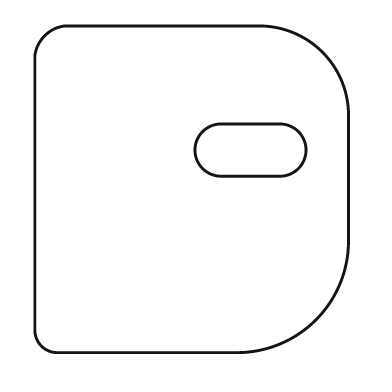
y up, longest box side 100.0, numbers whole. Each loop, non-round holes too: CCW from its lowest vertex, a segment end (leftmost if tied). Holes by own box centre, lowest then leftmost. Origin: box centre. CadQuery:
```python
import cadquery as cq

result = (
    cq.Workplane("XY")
    .moveTo(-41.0, -50.0)
    .lineTo(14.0, -50.0)
    .threePointArc((38.0, -40.0), (48.0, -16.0))
    .lineTo(48.0, 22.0)
    .threePointArc((40.0, 42.0), (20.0, 50.0))
    .lineTo(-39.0, 50.0)
    .threePointArc((-45.0, 47.0), (-48.0, 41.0))
    .lineTo(-48.0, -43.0)
    .threePointArc((-46.0, -48.0), (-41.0, -50.0))
    .close()
    .moveTo(9.0, 4.0)
    .lineTo(27.0, 4.0)
    .threePointArc((35.0, 12.0), (27.0, 20.0))
    .lineTo(9.0, 20.0)
    .threePointArc((1.0, 12.0), (9.0, 4.0))
    .close()
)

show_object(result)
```